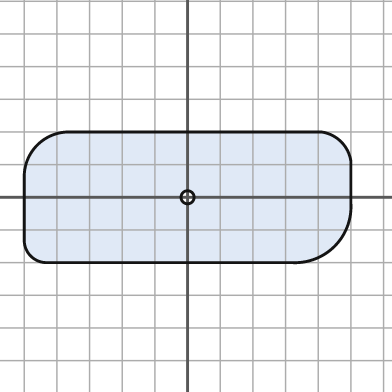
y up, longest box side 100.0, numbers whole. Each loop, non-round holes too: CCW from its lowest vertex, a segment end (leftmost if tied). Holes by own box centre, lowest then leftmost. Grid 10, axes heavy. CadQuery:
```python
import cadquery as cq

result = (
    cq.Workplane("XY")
    .moveTo(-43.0, -20.0)
    .lineTo(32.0, -20.0)
    .threePointArc((45.0, -15.0), (50.0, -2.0))
    .lineTo(50.0, 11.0)
    .threePointArc((47.0, 17.0), (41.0, 20.0))
    .lineTo(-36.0, 20.0)
    .threePointArc((-46.0, 16.0), (-50.0, 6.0))
    .lineTo(-50.0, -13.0)
    .threePointArc((-48.0, -18.0), (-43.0, -20.0))
    .close()
    .moveTo(0.0, 0.0)
    .circle(2.0)
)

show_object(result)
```